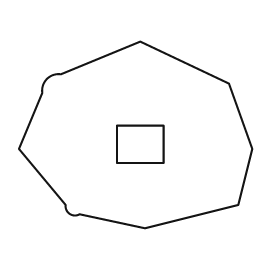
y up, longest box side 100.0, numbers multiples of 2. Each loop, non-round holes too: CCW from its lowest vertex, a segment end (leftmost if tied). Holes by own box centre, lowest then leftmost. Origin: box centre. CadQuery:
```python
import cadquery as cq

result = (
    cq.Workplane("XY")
    .moveTo(4.0, -40.0)
    .lineTo(44.0, -30.0)
    .lineTo(50.0, -6.0)
    .lineTo(40.0, 22.0)
    .lineTo(2.0, 40.0)
    .lineTo(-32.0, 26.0)
    .threePointArc((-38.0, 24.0), (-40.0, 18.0))
    .lineTo(-50.0, -6.0)
    .lineTo(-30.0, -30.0)
    .threePointArc((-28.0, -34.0), (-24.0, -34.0))
    .close()
    .moveTo(-8.0, -12.0)
    .lineTo(12.0, -12.0)
    .lineTo(12.0, 4.0)
    .lineTo(-8.0, 4.0)
    .close()
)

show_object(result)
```